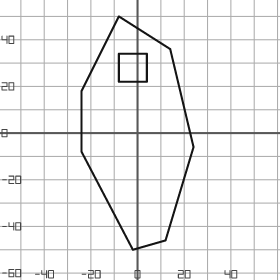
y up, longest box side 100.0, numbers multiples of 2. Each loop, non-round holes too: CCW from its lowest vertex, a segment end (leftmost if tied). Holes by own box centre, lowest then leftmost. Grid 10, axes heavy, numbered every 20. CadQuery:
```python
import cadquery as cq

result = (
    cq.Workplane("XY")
    .moveTo(-2.0, -50.0)
    .lineTo(12.0, -46.0)
    .lineTo(24.0, -6.0)
    .lineTo(14.0, 36.0)
    .lineTo(-8.0, 50.0)
    .lineTo(-24.0, 18.0)
    .lineTo(-24.0, -8.0)
    .close()
    .moveTo(-8.0, 22.0)
    .lineTo(4.0, 22.0)
    .lineTo(4.0, 34.0)
    .lineTo(-8.0, 34.0)
    .close()
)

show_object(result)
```